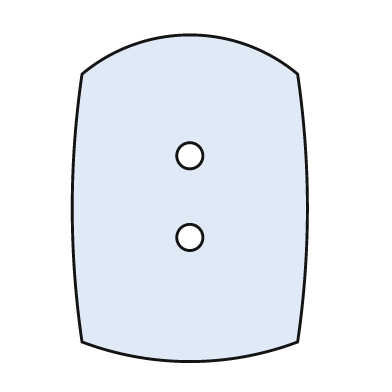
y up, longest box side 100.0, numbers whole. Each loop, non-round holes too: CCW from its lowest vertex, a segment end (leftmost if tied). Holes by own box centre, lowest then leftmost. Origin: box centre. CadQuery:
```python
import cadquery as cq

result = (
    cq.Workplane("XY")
    .moveTo(-33.0, -44.0)
    .threePointArc((0.0, -50.0), (33.0, -44.0))
    .threePointArc((36.0, -3.0), (33.0, 38.0))
    .threePointArc((0.0, 50.0), (-33.0, 38.0))
    .threePointArc((-36.0, -3.0), (-33.0, -44.0))
    .close()
    .moveTo(0.0, -12.0)
    .circle(4.0)
    .moveTo(0.0, 13.0)
    .circle(4.0)
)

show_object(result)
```